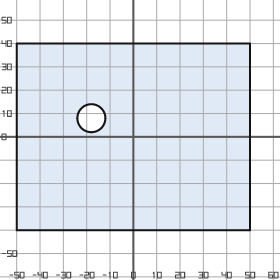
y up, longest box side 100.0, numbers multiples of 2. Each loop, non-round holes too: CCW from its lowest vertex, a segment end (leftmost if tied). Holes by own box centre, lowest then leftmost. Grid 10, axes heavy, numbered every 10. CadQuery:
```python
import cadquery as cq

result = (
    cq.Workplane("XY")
    .moveTo(-50.0, -40.0)
    .lineTo(50.0, -40.0)
    .lineTo(50.0, 40.0)
    .lineTo(-50.0, 40.0)
    .close()
    .moveTo(-18.0, 8.0)
    .circle(6.0)
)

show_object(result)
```